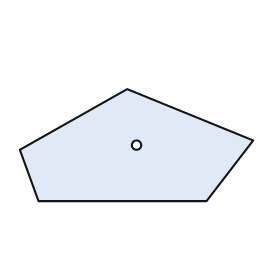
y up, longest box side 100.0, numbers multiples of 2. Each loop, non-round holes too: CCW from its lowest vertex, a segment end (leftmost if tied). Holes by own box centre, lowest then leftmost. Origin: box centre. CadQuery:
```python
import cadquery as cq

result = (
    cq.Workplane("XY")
    .moveTo(-42.0, -24.0)
    .lineTo(30.0, -24.0)
    .lineTo(50.0, 2.0)
    .lineTo(-4.0, 24.0)
    .lineTo(-50.0, -2.0)
    .close()
    .moveTo(0.0, 0.0)
    .circle(2.0)
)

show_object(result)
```